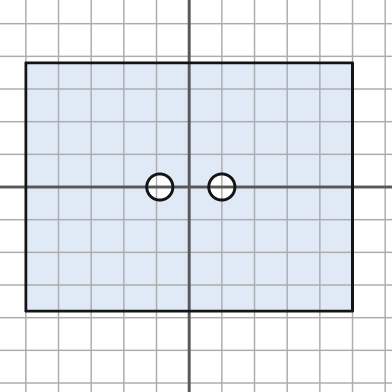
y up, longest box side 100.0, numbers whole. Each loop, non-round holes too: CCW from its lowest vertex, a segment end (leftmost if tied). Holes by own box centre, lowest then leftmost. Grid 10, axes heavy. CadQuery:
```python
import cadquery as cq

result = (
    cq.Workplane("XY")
    .moveTo(-50.0, -38.0)
    .lineTo(50.0, -38.0)
    .lineTo(50.0, 38.0)
    .lineTo(-50.0, 38.0)
    .close()
    .moveTo(-9.0, 0.0)
    .circle(4.0)
    .moveTo(10.0, 0.0)
    .circle(4.0)
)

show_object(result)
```